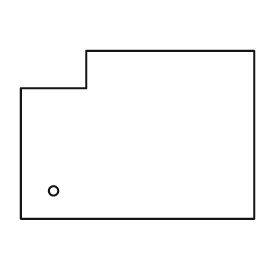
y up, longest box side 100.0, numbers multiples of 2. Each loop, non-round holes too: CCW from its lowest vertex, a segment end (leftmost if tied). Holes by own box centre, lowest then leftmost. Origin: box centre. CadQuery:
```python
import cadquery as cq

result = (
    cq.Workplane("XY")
    .moveTo(-50.0, -36.0)
    .lineTo(50.0, -36.0)
    .lineTo(50.0, 36.0)
    .lineTo(-22.0, 36.0)
    .lineTo(-22.0, 20.0)
    .lineTo(-50.0, 20.0)
    .close()
    .moveTo(-36.0, -24.0)
    .circle(2.0)
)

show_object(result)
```